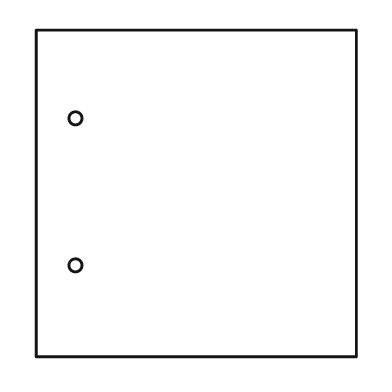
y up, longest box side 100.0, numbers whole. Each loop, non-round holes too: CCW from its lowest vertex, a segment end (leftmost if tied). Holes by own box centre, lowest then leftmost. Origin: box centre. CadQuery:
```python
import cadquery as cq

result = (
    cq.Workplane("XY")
    .moveTo(-49.0, -50.0)
    .lineTo(49.0, -50.0)
    .lineTo(49.0, 50.0)
    .lineTo(-49.0, 50.0)
    .close()
    .moveTo(-37.0, -22.0)
    .circle(2.0)
    .moveTo(-37.0, 23.0)
    .circle(2.0)
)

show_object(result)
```